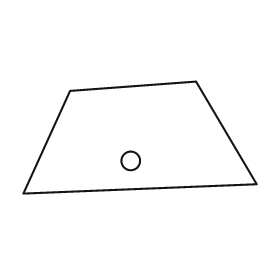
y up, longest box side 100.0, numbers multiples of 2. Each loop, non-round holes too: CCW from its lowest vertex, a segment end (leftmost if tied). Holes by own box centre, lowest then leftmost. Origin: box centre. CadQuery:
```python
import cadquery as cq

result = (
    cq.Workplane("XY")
    .moveTo(-50.0, -24.0)
    .lineTo(50.0, -20.0)
    .lineTo(24.0, 24.0)
    .lineTo(-30.0, 20.0)
    .close()
    .moveTo(-4.0, -10.0)
    .circle(4.0)
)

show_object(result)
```